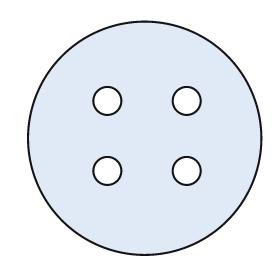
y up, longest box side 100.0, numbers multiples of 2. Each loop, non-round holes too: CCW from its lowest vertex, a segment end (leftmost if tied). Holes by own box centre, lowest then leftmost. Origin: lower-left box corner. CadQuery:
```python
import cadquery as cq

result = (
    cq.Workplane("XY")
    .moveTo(50.0, 50.0)
    .circle(50.0)
    .moveTo(34.0, 36.0)
    .circle(6.0)
    .moveTo(68.0, 36.0)
    .circle(6.0)
    .moveTo(34.0, 66.0)
    .circle(6.0)
    .moveTo(68.0, 66.0)
    .circle(6.0)
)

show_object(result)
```